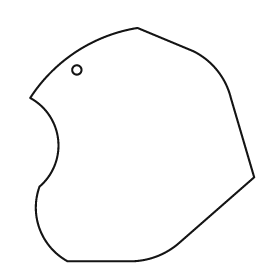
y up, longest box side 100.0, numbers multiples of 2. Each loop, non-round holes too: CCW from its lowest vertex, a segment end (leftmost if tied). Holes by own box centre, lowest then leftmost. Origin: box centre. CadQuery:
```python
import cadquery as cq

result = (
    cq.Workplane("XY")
    .moveTo(-32.0, -50.0)
    .lineTo(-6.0, -50.0)
    .threePointArc((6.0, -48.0), (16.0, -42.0))
    .lineTo(48.0, -14.0)
    .lineTo(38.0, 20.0)
    .threePointArc((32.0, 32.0), (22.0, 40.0))
    .lineTo(-2.0, 50.0)
    .threePointArc((-28.0, 40.0), (-48.0, 20.0))
    .threePointArc((-36.0, 2.0), (-44.0, -18.0))
    .threePointArc((-44.0, -36.0), (-32.0, -50.0))
    .close()
    .moveTo(-28.0, 32.0)
    .circle(2.0)
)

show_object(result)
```